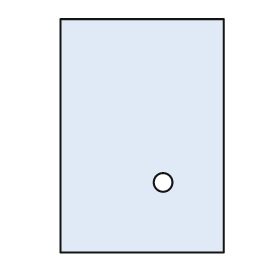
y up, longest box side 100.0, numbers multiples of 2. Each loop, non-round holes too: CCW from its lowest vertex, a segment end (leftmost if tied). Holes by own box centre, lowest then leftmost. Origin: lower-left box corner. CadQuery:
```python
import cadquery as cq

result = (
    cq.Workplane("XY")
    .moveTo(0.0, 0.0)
    .lineTo(70.0, 0.0)
    .lineTo(70.0, 100.0)
    .lineTo(0.0, 100.0)
    .close()
    .moveTo(44.0, 30.0)
    .circle(4.0)
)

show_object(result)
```